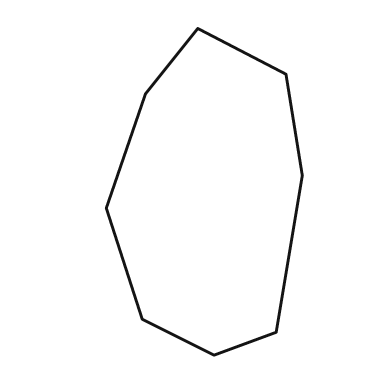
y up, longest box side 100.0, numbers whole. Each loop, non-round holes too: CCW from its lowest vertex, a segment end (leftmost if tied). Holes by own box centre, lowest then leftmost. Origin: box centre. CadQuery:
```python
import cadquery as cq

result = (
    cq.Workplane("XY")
    .moveTo(3.0, -50.0)
    .lineTo(22.0, -43.0)
    .lineTo(30.0, 5.0)
    .lineTo(25.0, 36.0)
    .lineTo(-2.0, 50.0)
    .lineTo(-18.0, 30.0)
    .lineTo(-30.0, -5.0)
    .lineTo(-19.0, -39.0)
    .close()
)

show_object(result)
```